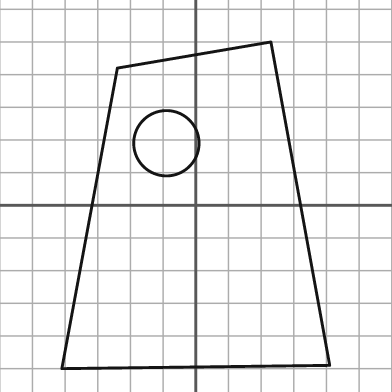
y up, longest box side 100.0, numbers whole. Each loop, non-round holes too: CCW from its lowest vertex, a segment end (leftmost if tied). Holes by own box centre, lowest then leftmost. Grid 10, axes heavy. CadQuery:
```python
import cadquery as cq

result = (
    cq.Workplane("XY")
    .moveTo(-41.0, -50.0)
    .lineTo(41.0, -49.0)
    .lineTo(23.0, 50.0)
    .lineTo(-24.0, 42.0)
    .close()
    .moveTo(-9.0, 19.0)
    .circle(10.0)
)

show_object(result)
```